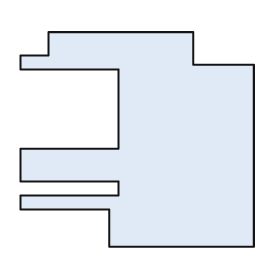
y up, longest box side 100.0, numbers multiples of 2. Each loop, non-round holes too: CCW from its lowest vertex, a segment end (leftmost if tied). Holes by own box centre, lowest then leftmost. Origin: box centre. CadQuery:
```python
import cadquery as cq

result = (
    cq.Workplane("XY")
    .moveTo(-12.0, -46.0)
    .lineTo(50.0, -46.0)
    .lineTo(50.0, 32.0)
    .lineTo(24.0, 32.0)
    .lineTo(24.0, 46.0)
    .lineTo(-38.0, 46.0)
    .lineTo(-38.0, 36.0)
    .lineTo(-50.0, 36.0)
    .lineTo(-50.0, 30.0)
    .lineTo(-8.0, 30.0)
    .lineTo(-8.0, -4.0)
    .lineTo(-50.0, -4.0)
    .lineTo(-50.0, -18.0)
    .lineTo(-8.0, -18.0)
    .lineTo(-8.0, -24.0)
    .lineTo(-50.0, -24.0)
    .lineTo(-50.0, -30.0)
    .lineTo(-12.0, -30.0)
    .close()
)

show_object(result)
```